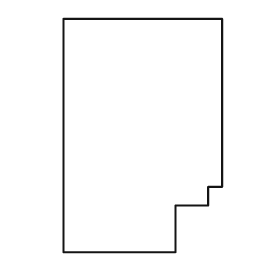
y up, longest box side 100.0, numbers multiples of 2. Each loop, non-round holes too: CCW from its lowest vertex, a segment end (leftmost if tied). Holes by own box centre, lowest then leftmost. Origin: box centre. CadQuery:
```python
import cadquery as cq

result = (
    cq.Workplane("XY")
    .moveTo(-34.0, -50.0)
    .lineTo(14.0, -50.0)
    .lineTo(14.0, -30.0)
    .lineTo(28.0, -30.0)
    .lineTo(28.0, -22.0)
    .lineTo(34.0, -22.0)
    .lineTo(34.0, 50.0)
    .lineTo(-34.0, 50.0)
    .close()
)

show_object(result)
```